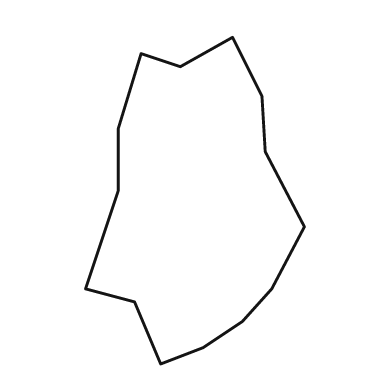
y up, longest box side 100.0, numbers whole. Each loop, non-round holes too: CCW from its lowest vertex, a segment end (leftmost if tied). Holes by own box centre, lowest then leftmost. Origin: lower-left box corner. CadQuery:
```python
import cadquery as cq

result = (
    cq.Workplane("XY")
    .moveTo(23.0, 0.0)
    .lineTo(36.0, 5.0)
    .lineTo(48.0, 13.0)
    .lineTo(57.0, 23.0)
    .lineTo(67.0, 42.0)
    .lineTo(55.0, 65.0)
    .lineTo(54.0, 82.0)
    .lineTo(45.0, 100.0)
    .lineTo(29.0, 91.0)
    .lineTo(17.0, 95.0)
    .lineTo(10.0, 72.0)
    .lineTo(10.0, 53.0)
    .lineTo(0.0, 23.0)
    .lineTo(15.0, 19.0)
    .close()
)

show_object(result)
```